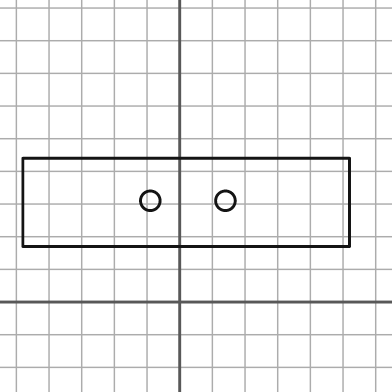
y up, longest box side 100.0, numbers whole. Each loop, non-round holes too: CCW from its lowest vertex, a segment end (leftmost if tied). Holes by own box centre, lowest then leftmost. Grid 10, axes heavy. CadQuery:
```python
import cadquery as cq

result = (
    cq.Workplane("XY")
    .moveTo(-48.0, 17.0)
    .lineTo(52.0, 17.0)
    .lineTo(52.0, 44.0)
    .lineTo(-48.0, 44.0)
    .close()
    .moveTo(-9.0, 31.0)
    .circle(3.0)
    .moveTo(14.0, 31.0)
    .circle(3.0)
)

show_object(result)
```